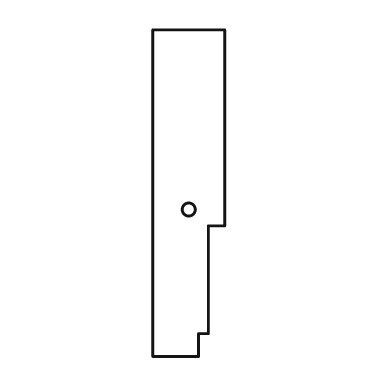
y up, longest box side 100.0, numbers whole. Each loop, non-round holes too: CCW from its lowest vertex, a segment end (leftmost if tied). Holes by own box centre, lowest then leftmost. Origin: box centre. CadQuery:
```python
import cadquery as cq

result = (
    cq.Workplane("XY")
    .moveTo(-11.0, -50.0)
    .lineTo(3.0, -50.0)
    .lineTo(3.0, -43.0)
    .lineTo(6.0, -43.0)
    .lineTo(6.0, -10.0)
    .lineTo(11.0, -10.0)
    .lineTo(11.0, 50.0)
    .lineTo(-11.0, 50.0)
    .close()
    .moveTo(0.0, -5.0)
    .circle(2.0)
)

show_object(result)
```